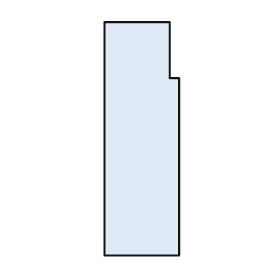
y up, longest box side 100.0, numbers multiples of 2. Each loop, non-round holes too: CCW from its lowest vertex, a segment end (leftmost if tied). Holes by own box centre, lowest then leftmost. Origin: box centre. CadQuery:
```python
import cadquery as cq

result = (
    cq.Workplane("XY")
    .moveTo(-16.0, -50.0)
    .lineTo(16.0, -50.0)
    .lineTo(16.0, 26.0)
    .lineTo(12.0, 26.0)
    .lineTo(12.0, 50.0)
    .lineTo(-16.0, 50.0)
    .close()
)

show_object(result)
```